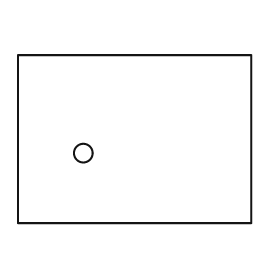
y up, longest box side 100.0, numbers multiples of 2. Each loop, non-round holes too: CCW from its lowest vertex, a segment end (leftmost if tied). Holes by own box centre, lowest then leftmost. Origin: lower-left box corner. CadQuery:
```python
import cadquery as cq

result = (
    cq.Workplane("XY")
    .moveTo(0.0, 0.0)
    .lineTo(100.0, 0.0)
    .lineTo(100.0, 72.0)
    .lineTo(0.0, 72.0)
    .close()
    .moveTo(28.0, 30.0)
    .circle(4.0)
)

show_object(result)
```